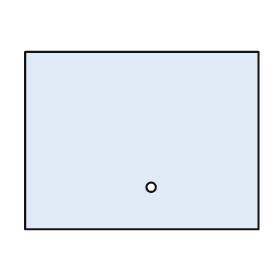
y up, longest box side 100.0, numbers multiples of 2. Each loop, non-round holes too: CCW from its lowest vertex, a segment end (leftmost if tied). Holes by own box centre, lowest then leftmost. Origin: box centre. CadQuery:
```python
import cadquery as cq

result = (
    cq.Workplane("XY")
    .moveTo(-50.0, -38.0)
    .lineTo(50.0, -38.0)
    .lineTo(50.0, 38.0)
    .lineTo(-50.0, 38.0)
    .close()
    .moveTo(4.0, -20.0)
    .circle(2.0)
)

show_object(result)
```